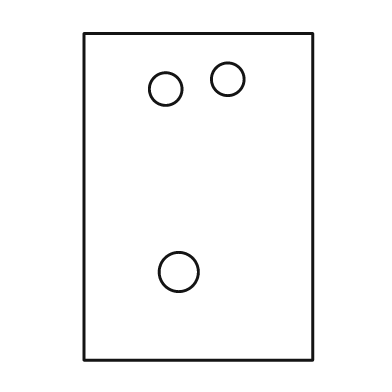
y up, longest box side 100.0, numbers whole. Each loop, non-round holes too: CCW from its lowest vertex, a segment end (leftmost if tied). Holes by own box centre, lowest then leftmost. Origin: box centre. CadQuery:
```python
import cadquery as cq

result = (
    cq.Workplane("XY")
    .moveTo(-35.0, -50.0)
    .lineTo(35.0, -50.0)
    .lineTo(35.0, 50.0)
    .lineTo(-35.0, 50.0)
    .close()
    .moveTo(-6.0, -23.0)
    .circle(6.0)
    .moveTo(-10.0, 33.0)
    .circle(5.0)
    .moveTo(9.0, 36.0)
    .circle(5.0)
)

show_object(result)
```